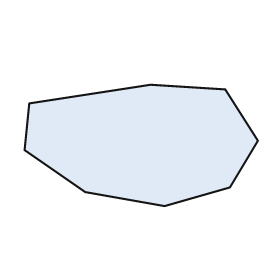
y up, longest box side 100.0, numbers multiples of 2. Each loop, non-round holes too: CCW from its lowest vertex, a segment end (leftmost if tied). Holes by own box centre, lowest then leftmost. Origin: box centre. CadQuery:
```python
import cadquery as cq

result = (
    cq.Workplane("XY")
    .moveTo(10.0, -26.0)
    .lineTo(38.0, -18.0)
    .lineTo(50.0, 2.0)
    .lineTo(36.0, 24.0)
    .lineTo(4.0, 26.0)
    .lineTo(-48.0, 18.0)
    .lineTo(-50.0, -2.0)
    .lineTo(-24.0, -20.0)
    .close()
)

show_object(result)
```